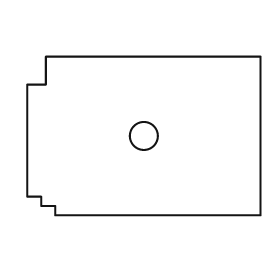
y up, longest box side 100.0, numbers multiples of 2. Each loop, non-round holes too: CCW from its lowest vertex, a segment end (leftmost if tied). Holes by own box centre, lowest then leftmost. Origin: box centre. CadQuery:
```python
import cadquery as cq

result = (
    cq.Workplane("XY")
    .moveTo(-38.0, -34.0)
    .lineTo(50.0, -34.0)
    .lineTo(50.0, 34.0)
    .lineTo(-42.0, 34.0)
    .lineTo(-42.0, 22.0)
    .lineTo(-50.0, 22.0)
    .lineTo(-50.0, -26.0)
    .lineTo(-44.0, -26.0)
    .lineTo(-44.0, -30.0)
    .lineTo(-38.0, -30.0)
    .close()
    .moveTo(0.0, 0.0)
    .circle(6.0)
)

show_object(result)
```